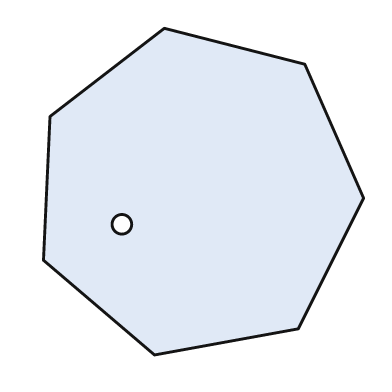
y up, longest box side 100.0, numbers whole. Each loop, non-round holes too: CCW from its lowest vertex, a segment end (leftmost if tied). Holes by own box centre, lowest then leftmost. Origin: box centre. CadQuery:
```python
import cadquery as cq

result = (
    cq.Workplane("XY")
    .moveTo(-15.0, -50.0)
    .lineTo(29.0, -42.0)
    .lineTo(49.0, -2.0)
    .lineTo(31.0, 39.0)
    .lineTo(-12.0, 50.0)
    .lineTo(-47.0, 23.0)
    .lineTo(-49.0, -21.0)
    .close()
    .moveTo(-25.0, -10.0)
    .circle(3.0)
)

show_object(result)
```